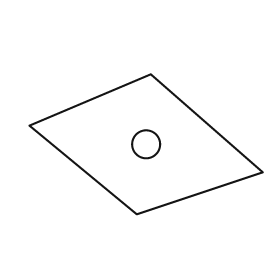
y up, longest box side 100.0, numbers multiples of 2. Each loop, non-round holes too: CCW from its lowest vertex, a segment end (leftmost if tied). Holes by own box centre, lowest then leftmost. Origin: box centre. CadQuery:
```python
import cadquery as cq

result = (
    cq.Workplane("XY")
    .moveTo(-4.0, -30.0)
    .lineTo(50.0, -12.0)
    .lineTo(2.0, 30.0)
    .lineTo(-50.0, 8.0)
    .close()
    .moveTo(0.0, 0.0)
    .circle(6.0)
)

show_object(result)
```